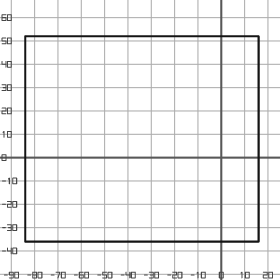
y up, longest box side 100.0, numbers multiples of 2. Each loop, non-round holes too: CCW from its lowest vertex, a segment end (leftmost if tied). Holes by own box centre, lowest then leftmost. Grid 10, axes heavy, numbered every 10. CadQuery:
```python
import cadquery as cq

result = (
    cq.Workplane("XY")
    .moveTo(-84.0, -36.0)
    .lineTo(16.0, -36.0)
    .lineTo(16.0, 52.0)
    .lineTo(-84.0, 52.0)
    .close()
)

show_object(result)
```